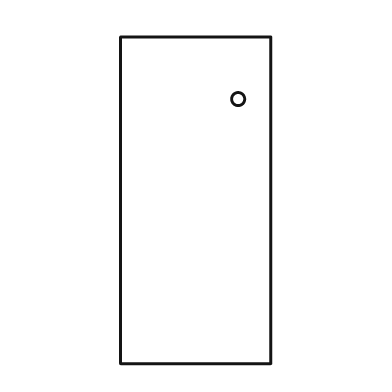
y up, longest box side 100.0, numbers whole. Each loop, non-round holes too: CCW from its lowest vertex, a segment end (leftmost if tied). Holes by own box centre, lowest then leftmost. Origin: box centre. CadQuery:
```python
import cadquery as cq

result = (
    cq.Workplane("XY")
    .moveTo(-23.0, -50.0)
    .lineTo(23.0, -50.0)
    .lineTo(23.0, 50.0)
    .lineTo(-23.0, 50.0)
    .close()
    .moveTo(13.0, 31.0)
    .circle(2.0)
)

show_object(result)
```